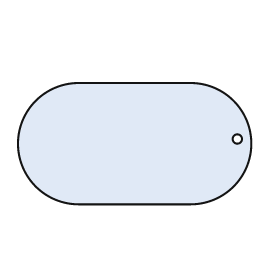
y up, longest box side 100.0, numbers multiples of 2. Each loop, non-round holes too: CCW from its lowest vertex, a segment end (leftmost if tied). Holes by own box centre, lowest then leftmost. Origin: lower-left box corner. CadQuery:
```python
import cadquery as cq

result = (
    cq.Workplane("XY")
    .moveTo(26.0, 0.0)
    .lineTo(74.0, 0.0)
    .threePointArc((100.0, 26.0), (74.0, 52.0))
    .lineTo(26.0, 52.0)
    .threePointArc((0.0, 26.0), (26.0, 0.0))
    .close()
    .moveTo(94.0, 28.0)
    .circle(2.0)
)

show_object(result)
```